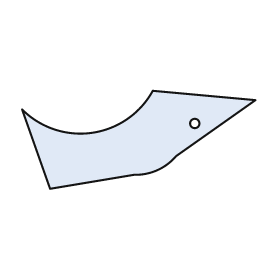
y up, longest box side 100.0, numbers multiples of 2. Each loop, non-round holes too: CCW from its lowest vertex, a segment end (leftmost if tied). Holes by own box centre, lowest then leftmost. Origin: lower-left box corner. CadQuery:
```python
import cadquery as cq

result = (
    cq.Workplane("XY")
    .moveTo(12.0, 0.0)
    .lineTo(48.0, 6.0)
    .threePointArc((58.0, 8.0), (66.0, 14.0))
    .lineTo(100.0, 38.0)
    .lineTo(56.0, 42.0)
    .threePointArc((30.0, 24.0), (0.0, 34.0))
    .close()
    .moveTo(74.0, 28.0)
    .circle(2.0)
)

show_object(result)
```